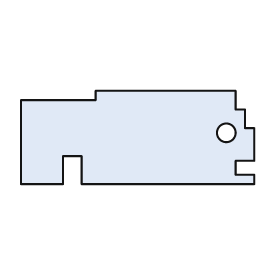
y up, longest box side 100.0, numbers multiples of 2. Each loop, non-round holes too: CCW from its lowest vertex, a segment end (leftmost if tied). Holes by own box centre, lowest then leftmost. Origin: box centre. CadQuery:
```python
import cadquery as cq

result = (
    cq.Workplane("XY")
    .moveTo(-50.0, -20.0)
    .lineTo(-32.0, -20.0)
    .lineTo(-32.0, -8.0)
    .lineTo(-24.0, -8.0)
    .lineTo(-24.0, -20.0)
    .lineTo(50.0, -20.0)
    .lineTo(50.0, -16.0)
    .lineTo(42.0, -16.0)
    .lineTo(42.0, -10.0)
    .lineTo(50.0, -10.0)
    .lineTo(50.0, 4.0)
    .lineTo(46.0, 4.0)
    .lineTo(46.0, 12.0)
    .lineTo(42.0, 12.0)
    .lineTo(42.0, 20.0)
    .lineTo(-18.0, 20.0)
    .lineTo(-18.0, 16.0)
    .lineTo(-50.0, 16.0)
    .close()
    .moveTo(38.0, 2.0)
    .circle(4.0)
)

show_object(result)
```